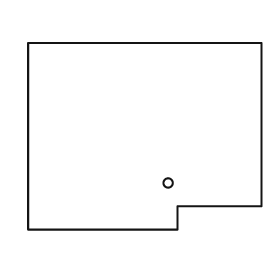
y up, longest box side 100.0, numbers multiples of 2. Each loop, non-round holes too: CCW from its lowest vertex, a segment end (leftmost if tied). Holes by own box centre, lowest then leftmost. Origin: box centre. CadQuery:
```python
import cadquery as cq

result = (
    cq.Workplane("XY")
    .moveTo(-50.0, -40.0)
    .lineTo(14.0, -40.0)
    .lineTo(14.0, -30.0)
    .lineTo(50.0, -30.0)
    .lineTo(50.0, 40.0)
    .lineTo(-50.0, 40.0)
    .close()
    .moveTo(10.0, -20.0)
    .circle(2.0)
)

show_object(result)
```